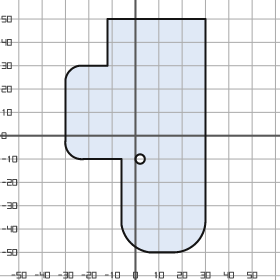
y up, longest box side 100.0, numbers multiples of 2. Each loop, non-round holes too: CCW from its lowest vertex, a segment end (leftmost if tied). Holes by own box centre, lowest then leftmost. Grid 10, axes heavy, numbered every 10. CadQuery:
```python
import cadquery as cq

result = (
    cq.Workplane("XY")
    .moveTo(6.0, -50.0)
    .lineTo(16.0, -50.0)
    .threePointArc((26.0, -46.0), (30.0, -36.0))
    .lineTo(30.0, 50.0)
    .lineTo(-12.0, 50.0)
    .lineTo(-12.0, 30.0)
    .lineTo(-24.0, 30.0)
    .threePointArc((-28.0, 28.0), (-30.0, 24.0))
    .lineTo(-30.0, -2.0)
    .threePointArc((-28.0, -8.0), (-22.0, -10.0))
    .lineTo(-6.0, -10.0)
    .lineTo(-6.0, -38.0)
    .threePointArc((-2.0, -46.0), (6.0, -50.0))
    .close()
    .moveTo(2.0, -10.0)
    .circle(2.0)
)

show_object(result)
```